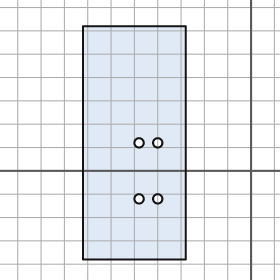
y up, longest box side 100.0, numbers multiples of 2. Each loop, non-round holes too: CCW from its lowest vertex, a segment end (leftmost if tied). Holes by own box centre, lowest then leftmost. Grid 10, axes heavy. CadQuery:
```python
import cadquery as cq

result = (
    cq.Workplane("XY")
    .moveTo(-72.0, -38.0)
    .lineTo(-28.0, -38.0)
    .lineTo(-28.0, 62.0)
    .lineTo(-72.0, 62.0)
    .close()
    .moveTo(-48.0, -12.0)
    .circle(2.0)
    .moveTo(-40.0, -12.0)
    .circle(2.0)
    .moveTo(-48.0, 12.0)
    .circle(2.0)
    .moveTo(-40.0, 12.0)
    .circle(2.0)
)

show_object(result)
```